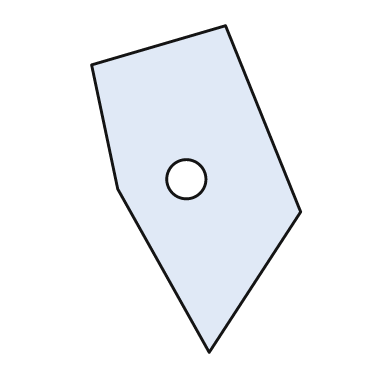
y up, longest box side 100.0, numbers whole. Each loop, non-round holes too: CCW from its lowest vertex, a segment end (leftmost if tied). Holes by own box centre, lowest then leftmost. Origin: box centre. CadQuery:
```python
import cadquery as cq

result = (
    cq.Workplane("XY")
    .moveTo(4.0, -50.0)
    .lineTo(32.0, -7.0)
    .lineTo(9.0, 50.0)
    .lineTo(-32.0, 38.0)
    .lineTo(-24.0, 0.0)
    .close()
    .moveTo(-3.0, 3.0)
    .circle(6.0)
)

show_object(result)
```